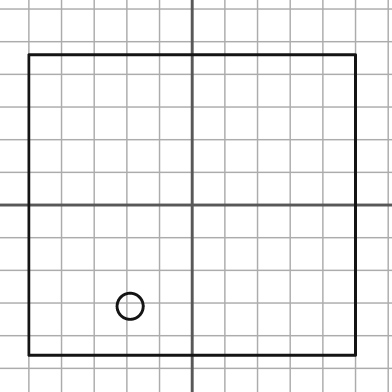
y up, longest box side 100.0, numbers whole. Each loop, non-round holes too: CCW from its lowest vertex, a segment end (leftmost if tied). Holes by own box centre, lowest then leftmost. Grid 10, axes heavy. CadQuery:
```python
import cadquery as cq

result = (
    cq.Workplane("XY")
    .moveTo(-50.0, -46.0)
    .lineTo(50.0, -46.0)
    .lineTo(50.0, 46.0)
    .lineTo(-50.0, 46.0)
    .close()
    .moveTo(-19.0, -31.0)
    .circle(4.0)
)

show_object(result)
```